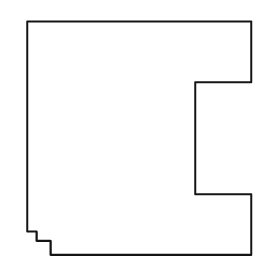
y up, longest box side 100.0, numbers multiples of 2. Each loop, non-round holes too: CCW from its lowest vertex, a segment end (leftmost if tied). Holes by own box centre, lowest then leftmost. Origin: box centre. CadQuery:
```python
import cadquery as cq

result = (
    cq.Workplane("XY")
    .moveTo(-38.0, -50.0)
    .lineTo(48.0, -50.0)
    .lineTo(48.0, -24.0)
    .lineTo(24.0, -24.0)
    .lineTo(24.0, 24.0)
    .lineTo(48.0, 24.0)
    .lineTo(48.0, 50.0)
    .lineTo(-48.0, 50.0)
    .lineTo(-48.0, -40.0)
    .lineTo(-44.0, -40.0)
    .lineTo(-44.0, -44.0)
    .lineTo(-38.0, -44.0)
    .close()
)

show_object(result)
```